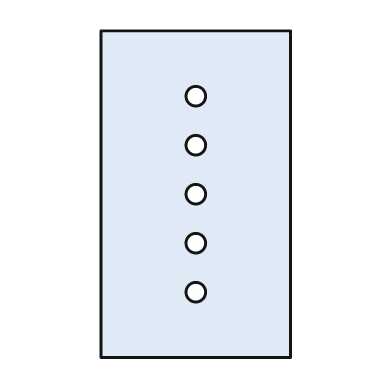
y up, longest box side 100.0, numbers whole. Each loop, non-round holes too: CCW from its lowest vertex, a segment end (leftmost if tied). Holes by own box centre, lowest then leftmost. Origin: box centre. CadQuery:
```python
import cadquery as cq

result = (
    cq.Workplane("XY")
    .moveTo(-29.0, -50.0)
    .lineTo(29.0, -50.0)
    .lineTo(29.0, 50.0)
    .lineTo(-29.0, 50.0)
    .close()
    .moveTo(0.0, -30.0)
    .circle(3.0)
    .moveTo(0.0, -15.0)
    .circle(3.0)
    .moveTo(0.0, 0.0)
    .circle(3.0)
    .moveTo(0.0, 15.0)
    .circle(3.0)
    .moveTo(0.0, 30.0)
    .circle(3.0)
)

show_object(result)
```